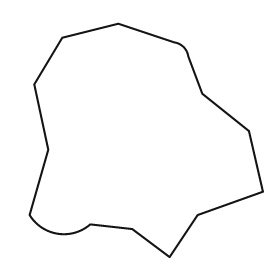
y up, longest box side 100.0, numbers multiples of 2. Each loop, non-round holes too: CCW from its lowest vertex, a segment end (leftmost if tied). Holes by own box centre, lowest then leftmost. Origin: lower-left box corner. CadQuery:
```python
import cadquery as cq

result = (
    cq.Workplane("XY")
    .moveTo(60.0, 0.0)
    .lineTo(72.0, 18.0)
    .lineTo(100.0, 28.0)
    .lineTo(94.0, 54.0)
    .lineTo(74.0, 70.0)
    .lineTo(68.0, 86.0)
    .threePointArc((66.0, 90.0), (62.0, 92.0))
    .lineTo(38.0, 100.0)
    .lineTo(14.0, 94.0)
    .lineTo(2.0, 74.0)
    .lineTo(8.0, 46.0)
    .lineTo(0.0, 18.0)
    .threePointArc((12.0, 10.0), (26.0, 14.0))
    .lineTo(44.0, 12.0)
    .close()
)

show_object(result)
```